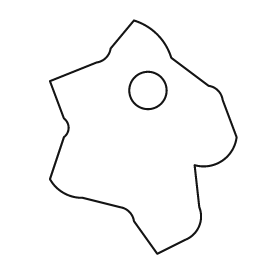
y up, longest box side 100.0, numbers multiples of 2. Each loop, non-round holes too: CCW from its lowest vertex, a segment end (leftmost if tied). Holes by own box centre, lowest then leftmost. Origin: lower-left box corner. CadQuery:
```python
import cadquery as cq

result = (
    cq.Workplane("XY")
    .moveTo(46.0, 0.0)
    .lineTo(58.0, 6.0)
    .threePointArc((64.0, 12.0), (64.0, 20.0))
    .lineTo(62.0, 38.0)
    .threePointArc((74.0, 40.0), (80.0, 50.0))
    .lineTo(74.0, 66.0)
    .threePointArc((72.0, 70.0), (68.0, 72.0))
    .lineTo(52.0, 84.0)
    .threePointArc((46.0, 94.0), (36.0, 100.0))
    .lineTo(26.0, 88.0)
    .threePointArc((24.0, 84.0), (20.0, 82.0))
    .lineTo(0.0, 74.0)
    .lineTo(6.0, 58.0)
    .threePointArc((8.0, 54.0), (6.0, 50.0))
    .lineTo(0.0, 32.0)
    .threePointArc((6.0, 26.0), (14.0, 24.0))
    .lineTo(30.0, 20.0)
    .threePointArc((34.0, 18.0), (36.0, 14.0))
    .close()
    .moveTo(42.0, 70.0)
    .circle(8.0)
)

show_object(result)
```